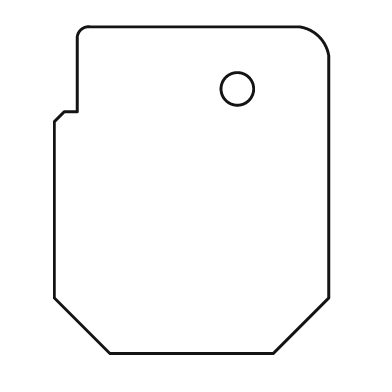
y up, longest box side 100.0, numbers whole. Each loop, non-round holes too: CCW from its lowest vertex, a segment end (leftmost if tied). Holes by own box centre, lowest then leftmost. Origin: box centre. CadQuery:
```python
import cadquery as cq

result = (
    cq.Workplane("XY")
    .moveTo(-25.0, -50.0)
    .lineTo(25.0, -50.0)
    .lineTo(42.0, -33.0)
    .lineTo(42.0, 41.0)
    .threePointArc((39.0, 47.0), (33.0, 50.0))
    .lineTo(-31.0, 50.0)
    .threePointArc((-34.0, 49.0), (-35.0, 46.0))
    .lineTo(-35.0, 24.0)
    .lineTo(-39.0, 24.0)
    .lineTo(-42.0, 21.0)
    .lineTo(-42.0, -33.0)
    .close()
    .moveTo(14.0, 31.0)
    .circle(5.0)
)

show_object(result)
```